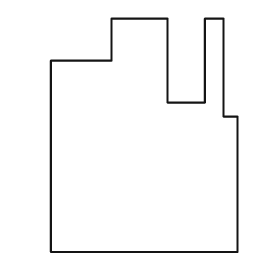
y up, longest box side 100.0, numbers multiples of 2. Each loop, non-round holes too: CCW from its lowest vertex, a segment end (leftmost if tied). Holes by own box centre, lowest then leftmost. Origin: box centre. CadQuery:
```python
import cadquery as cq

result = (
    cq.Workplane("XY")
    .moveTo(-40.0, -50.0)
    .lineTo(40.0, -50.0)
    .lineTo(40.0, 8.0)
    .lineTo(34.0, 8.0)
    .lineTo(34.0, 50.0)
    .lineTo(26.0, 50.0)
    .lineTo(26.0, 14.0)
    .lineTo(10.0, 14.0)
    .lineTo(10.0, 50.0)
    .lineTo(-14.0, 50.0)
    .lineTo(-14.0, 32.0)
    .lineTo(-40.0, 32.0)
    .close()
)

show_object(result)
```